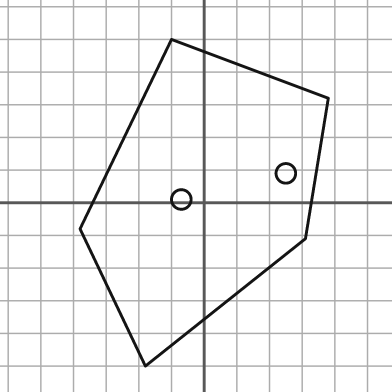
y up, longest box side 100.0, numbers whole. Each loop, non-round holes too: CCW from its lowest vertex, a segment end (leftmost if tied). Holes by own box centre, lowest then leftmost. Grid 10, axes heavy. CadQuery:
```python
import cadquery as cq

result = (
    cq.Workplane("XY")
    .moveTo(-18.0, -50.0)
    .lineTo(31.0, -11.0)
    .lineTo(38.0, 32.0)
    .lineTo(-10.0, 50.0)
    .lineTo(-38.0, -8.0)
    .close()
    .moveTo(-7.0, 1.0)
    .circle(3.0)
    .moveTo(25.0, 9.0)
    .circle(3.0)
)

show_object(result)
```